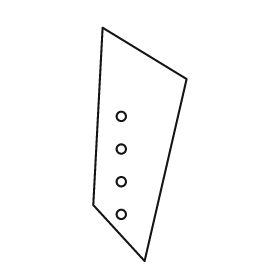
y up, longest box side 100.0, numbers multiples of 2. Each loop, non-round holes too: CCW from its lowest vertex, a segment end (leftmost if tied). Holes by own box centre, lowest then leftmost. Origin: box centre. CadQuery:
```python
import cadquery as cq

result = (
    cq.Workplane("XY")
    .moveTo(2.0, -50.0)
    .lineTo(20.0, 28.0)
    .lineTo(-16.0, 50.0)
    .lineTo(-20.0, -26.0)
    .close()
    .moveTo(-8.0, -30.0)
    .circle(2.0)
    .moveTo(-8.0, -16.0)
    .circle(2.0)
    .moveTo(-8.0, -2.0)
    .circle(2.0)
    .moveTo(-8.0, 12.0)
    .circle(2.0)
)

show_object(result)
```